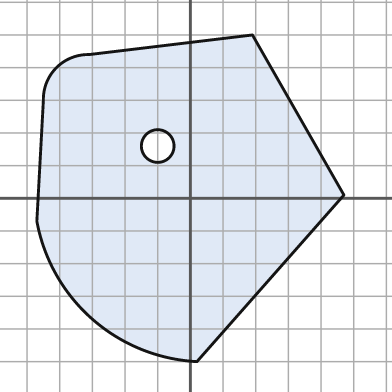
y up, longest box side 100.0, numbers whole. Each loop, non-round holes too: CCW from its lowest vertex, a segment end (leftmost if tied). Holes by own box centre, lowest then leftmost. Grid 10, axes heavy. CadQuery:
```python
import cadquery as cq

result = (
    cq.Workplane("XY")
    .moveTo(2.0, -50.0)
    .lineTo(47.0, 1.0)
    .lineTo(19.0, 50.0)
    .lineTo(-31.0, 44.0)
    .threePointArc((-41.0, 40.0), (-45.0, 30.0))
    .lineTo(-47.0, -7.0)
    .threePointArc((-30.0, -37.0), (2.0, -50.0))
    .close()
    .moveTo(-10.0, 16.0)
    .circle(5.0)
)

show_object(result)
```